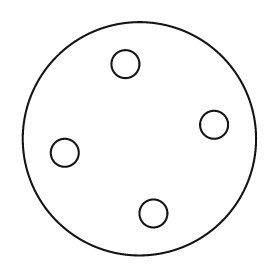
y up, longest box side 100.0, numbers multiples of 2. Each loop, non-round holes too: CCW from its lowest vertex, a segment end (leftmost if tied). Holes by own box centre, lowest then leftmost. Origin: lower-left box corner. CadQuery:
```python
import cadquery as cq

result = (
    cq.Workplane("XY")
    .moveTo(50.0, 50.0)
    .circle(50.0)
    .moveTo(56.0, 18.0)
    .circle(6.0)
    .moveTo(18.0, 44.0)
    .circle(6.0)
    .moveTo(82.0, 56.0)
    .circle(6.0)
    .moveTo(44.0, 82.0)
    .circle(6.0)
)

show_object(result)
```